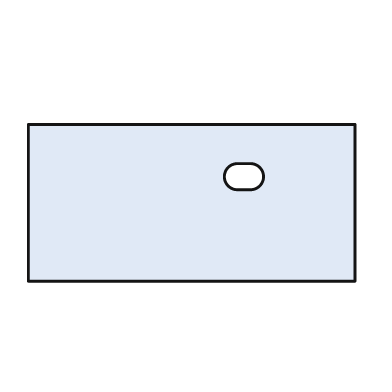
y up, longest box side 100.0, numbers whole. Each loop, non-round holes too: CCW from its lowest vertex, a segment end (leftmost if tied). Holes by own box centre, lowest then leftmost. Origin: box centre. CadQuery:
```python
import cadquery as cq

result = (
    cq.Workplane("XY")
    .moveTo(-50.0, -24.0)
    .lineTo(50.0, -24.0)
    .lineTo(50.0, 24.0)
    .lineTo(-50.0, 24.0)
    .close()
    .moveTo(14.0, 4.0)
    .lineTo(18.0, 4.0)
    .threePointArc((22.0, 8.0), (18.0, 12.0))
    .lineTo(14.0, 12.0)
    .threePointArc((10.0, 8.0), (14.0, 4.0))
    .close()
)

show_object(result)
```